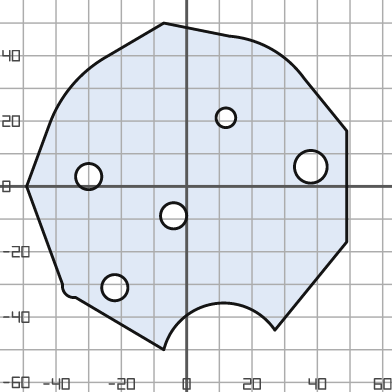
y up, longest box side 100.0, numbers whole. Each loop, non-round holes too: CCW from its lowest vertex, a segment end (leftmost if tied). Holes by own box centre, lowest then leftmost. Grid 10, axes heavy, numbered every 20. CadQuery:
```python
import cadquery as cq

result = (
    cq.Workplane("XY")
    .moveTo(-7.0, -50.0)
    .threePointArc((8.0, -36.0), (27.0, -44.0))
    .lineTo(49.0, -17.0)
    .lineTo(49.0, 17.0)
    .lineTo(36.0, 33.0)
    .threePointArc((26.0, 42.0), (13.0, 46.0))
    .lineTo(-7.0, 50.0)
    .lineTo(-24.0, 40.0)
    .threePointArc((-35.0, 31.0), (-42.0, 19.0))
    .lineTo(-49.0, 0.0)
    .lineTo(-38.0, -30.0)
    .threePointArc((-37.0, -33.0), (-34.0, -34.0))
    .close()
    .moveTo(-22.0, -31.0)
    .circle(4.0)
    .moveTo(-4.0, -9.0)
    .circle(4.0)
    .moveTo(-30.0, 3.0)
    .circle(4.0)
    .moveTo(38.0, 6.0)
    .circle(5.0)
    .moveTo(12.0, 21.0)
    .circle(3.0)
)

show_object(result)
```